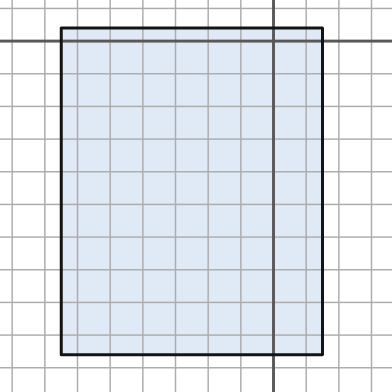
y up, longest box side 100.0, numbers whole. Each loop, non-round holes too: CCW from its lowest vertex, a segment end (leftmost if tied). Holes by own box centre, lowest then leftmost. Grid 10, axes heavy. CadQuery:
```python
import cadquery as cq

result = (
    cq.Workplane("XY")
    .moveTo(-65.0, -96.0)
    .lineTo(15.0, -96.0)
    .lineTo(15.0, 4.0)
    .lineTo(-65.0, 4.0)
    .close()
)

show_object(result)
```